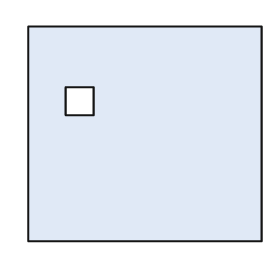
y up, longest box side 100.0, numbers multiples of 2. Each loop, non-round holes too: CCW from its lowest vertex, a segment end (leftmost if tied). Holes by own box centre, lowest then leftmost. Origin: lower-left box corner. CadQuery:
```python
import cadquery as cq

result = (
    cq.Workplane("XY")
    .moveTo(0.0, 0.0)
    .lineTo(100.0, 0.0)
    .lineTo(100.0, 92.0)
    .lineTo(0.0, 92.0)
    .close()
    .moveTo(16.0, 54.0)
    .lineTo(28.0, 54.0)
    .lineTo(28.0, 66.0)
    .lineTo(16.0, 66.0)
    .close()
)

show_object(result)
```